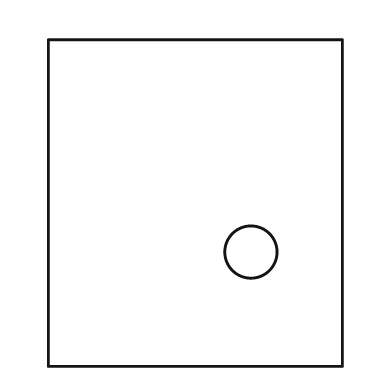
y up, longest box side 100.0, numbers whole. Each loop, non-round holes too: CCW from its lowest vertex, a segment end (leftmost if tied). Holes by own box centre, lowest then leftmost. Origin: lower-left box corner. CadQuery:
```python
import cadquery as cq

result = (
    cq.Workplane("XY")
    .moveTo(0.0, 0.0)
    .lineTo(90.0, 0.0)
    .lineTo(90.0, 100.0)
    .lineTo(0.0, 100.0)
    .close()
    .moveTo(62.0, 35.0)
    .circle(8.0)
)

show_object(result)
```